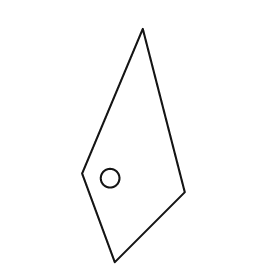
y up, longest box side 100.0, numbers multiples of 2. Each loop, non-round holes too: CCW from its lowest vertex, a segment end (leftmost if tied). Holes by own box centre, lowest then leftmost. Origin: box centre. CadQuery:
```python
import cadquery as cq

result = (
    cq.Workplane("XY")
    .moveTo(-8.0, -50.0)
    .lineTo(22.0, -20.0)
    .lineTo(4.0, 50.0)
    .lineTo(-22.0, -12.0)
    .close()
    .moveTo(-10.0, -14.0)
    .circle(4.0)
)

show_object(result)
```